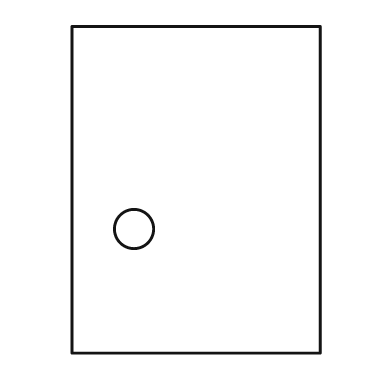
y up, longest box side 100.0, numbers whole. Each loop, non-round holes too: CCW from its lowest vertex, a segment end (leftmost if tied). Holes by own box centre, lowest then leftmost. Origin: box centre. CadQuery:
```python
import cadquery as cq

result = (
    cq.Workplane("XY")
    .moveTo(-38.0, -50.0)
    .lineTo(38.0, -50.0)
    .lineTo(38.0, 50.0)
    .lineTo(-38.0, 50.0)
    .close()
    .moveTo(-19.0, -12.0)
    .circle(6.0)
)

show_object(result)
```